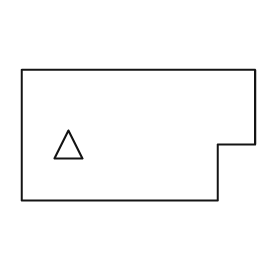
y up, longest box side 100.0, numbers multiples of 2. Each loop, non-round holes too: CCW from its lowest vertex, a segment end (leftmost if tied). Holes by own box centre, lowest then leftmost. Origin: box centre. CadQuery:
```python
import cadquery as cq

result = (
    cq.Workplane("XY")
    .moveTo(-50.0, -28.0)
    .lineTo(34.0, -28.0)
    .lineTo(34.0, -4.0)
    .lineTo(50.0, -4.0)
    .lineTo(50.0, 28.0)
    .lineTo(-50.0, 28.0)
    .close()
    .moveTo(-36.0, -10.0)
    .lineTo(-24.0, -10.0)
    .lineTo(-30.0, 2.0)
    .close()
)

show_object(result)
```